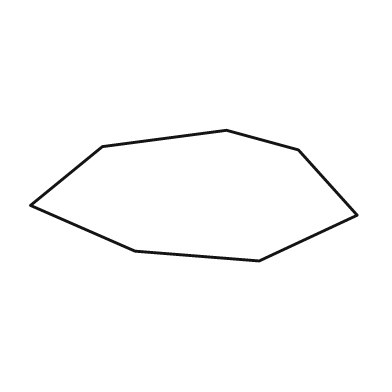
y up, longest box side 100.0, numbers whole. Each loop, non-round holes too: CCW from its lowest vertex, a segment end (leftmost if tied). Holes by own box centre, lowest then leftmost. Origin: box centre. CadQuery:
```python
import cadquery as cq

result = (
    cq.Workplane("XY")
    .moveTo(20.0, -20.0)
    .lineTo(50.0, -6.0)
    .lineTo(32.0, 14.0)
    .lineTo(10.0, 20.0)
    .lineTo(-28.0, 15.0)
    .lineTo(-50.0, -3.0)
    .lineTo(-18.0, -17.0)
    .close()
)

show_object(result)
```